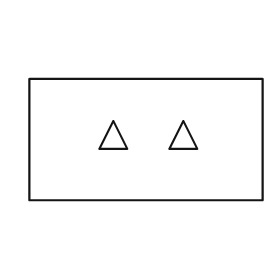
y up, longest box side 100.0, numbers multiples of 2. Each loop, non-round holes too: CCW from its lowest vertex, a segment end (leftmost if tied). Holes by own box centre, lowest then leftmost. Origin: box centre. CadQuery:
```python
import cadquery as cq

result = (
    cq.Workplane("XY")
    .moveTo(-50.0, -26.0)
    .lineTo(50.0, -26.0)
    .lineTo(50.0, 26.0)
    .lineTo(-50.0, 26.0)
    .close()
    .moveTo(-20.0, -4.0)
    .lineTo(-8.0, -4.0)
    .lineTo(-14.0, 8.0)
    .close()
    .moveTo(10.0, -4.0)
    .lineTo(22.0, -4.0)
    .lineTo(16.0, 8.0)
    .close()
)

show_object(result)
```